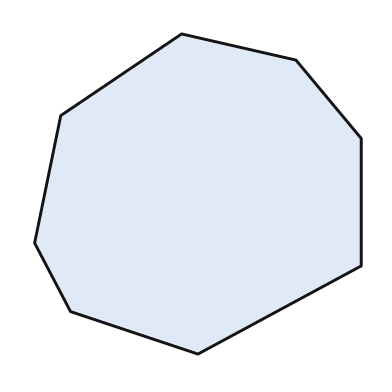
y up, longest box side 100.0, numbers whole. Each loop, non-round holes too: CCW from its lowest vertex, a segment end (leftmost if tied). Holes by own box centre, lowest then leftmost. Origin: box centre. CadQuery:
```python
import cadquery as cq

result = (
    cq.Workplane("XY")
    .moveTo(0.0, -49.0)
    .lineTo(50.0, -22.0)
    .lineTo(50.0, 17.0)
    .lineTo(30.0, 41.0)
    .lineTo(-5.0, 49.0)
    .lineTo(-42.0, 24.0)
    .lineTo(-50.0, -15.0)
    .lineTo(-39.0, -36.0)
    .close()
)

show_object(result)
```